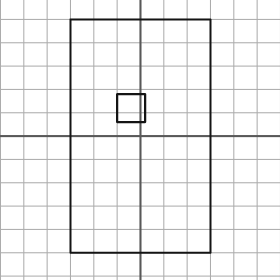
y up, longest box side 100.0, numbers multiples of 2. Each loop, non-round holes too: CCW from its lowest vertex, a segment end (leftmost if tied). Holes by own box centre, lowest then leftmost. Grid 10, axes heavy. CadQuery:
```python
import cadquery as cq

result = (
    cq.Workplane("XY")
    .moveTo(-30.0, -50.0)
    .lineTo(30.0, -50.0)
    .lineTo(30.0, 50.0)
    .lineTo(-30.0, 50.0)
    .close()
    .moveTo(-10.0, 6.0)
    .lineTo(2.0, 6.0)
    .lineTo(2.0, 18.0)
    .lineTo(-10.0, 18.0)
    .close()
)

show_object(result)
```